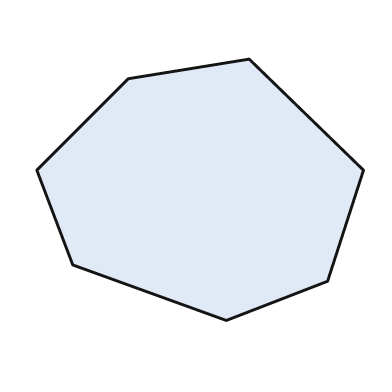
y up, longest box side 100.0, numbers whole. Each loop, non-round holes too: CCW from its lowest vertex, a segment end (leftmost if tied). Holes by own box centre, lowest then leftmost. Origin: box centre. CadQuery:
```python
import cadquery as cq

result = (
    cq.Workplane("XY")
    .moveTo(8.0, -40.0)
    .lineTo(39.0, -28.0)
    .lineTo(50.0, 6.0)
    .lineTo(15.0, 40.0)
    .lineTo(-22.0, 34.0)
    .lineTo(-50.0, 6.0)
    .lineTo(-39.0, -23.0)
    .close()
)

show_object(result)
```